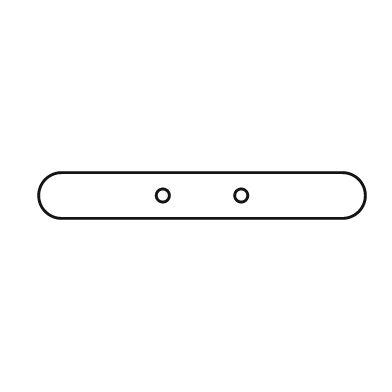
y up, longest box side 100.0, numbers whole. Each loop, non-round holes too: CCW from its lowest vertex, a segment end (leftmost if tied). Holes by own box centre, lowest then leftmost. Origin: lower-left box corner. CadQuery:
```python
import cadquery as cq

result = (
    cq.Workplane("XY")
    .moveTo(7.0, 0.0)
    .lineTo(93.0, 0.0)
    .threePointArc((100.0, 7.0), (93.0, 14.0))
    .lineTo(7.0, 14.0)
    .threePointArc((0.0, 7.0), (7.0, 0.0))
    .close()
    .moveTo(38.0, 7.0)
    .circle(2.0)
    .moveTo(62.0, 7.0)
    .circle(2.0)
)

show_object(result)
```